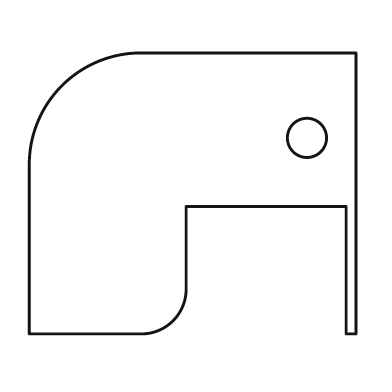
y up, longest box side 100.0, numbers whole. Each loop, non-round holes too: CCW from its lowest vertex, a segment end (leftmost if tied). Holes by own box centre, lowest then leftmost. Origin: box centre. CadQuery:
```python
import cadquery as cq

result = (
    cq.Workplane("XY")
    .moveTo(-50.0, -43.0)
    .lineTo(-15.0, -43.0)
    .threePointArc((-6.0, -39.0), (-2.0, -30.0))
    .lineTo(-2.0, -4.0)
    .lineTo(47.0, -4.0)
    .lineTo(47.0, -43.0)
    .lineTo(50.0, -43.0)
    .lineTo(50.0, 43.0)
    .lineTo(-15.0, 43.0)
    .threePointArc((-40.0, 33.0), (-50.0, 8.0))
    .close()
    .moveTo(35.0, 17.0)
    .circle(6.0)
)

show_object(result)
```